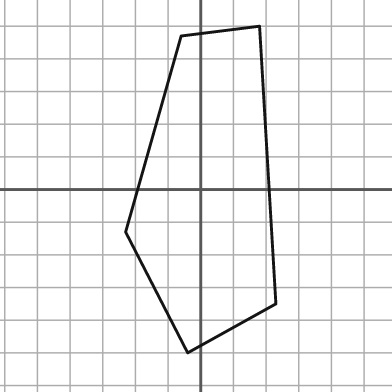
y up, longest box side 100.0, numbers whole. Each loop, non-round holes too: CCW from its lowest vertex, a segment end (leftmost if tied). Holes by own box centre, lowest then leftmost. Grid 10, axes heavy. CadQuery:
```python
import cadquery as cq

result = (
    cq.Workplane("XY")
    .moveTo(-4.0, -50.0)
    .lineTo(23.0, -35.0)
    .lineTo(18.0, 50.0)
    .lineTo(-6.0, 47.0)
    .lineTo(-23.0, -13.0)
    .close()
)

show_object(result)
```